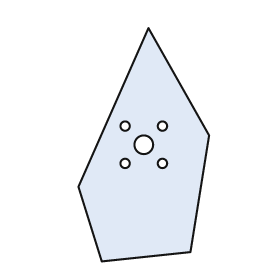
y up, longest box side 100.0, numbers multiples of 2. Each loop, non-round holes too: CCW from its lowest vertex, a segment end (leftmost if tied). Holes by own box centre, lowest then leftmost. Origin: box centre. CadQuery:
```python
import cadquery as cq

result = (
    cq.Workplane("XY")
    .moveTo(-18.0, -50.0)
    .lineTo(20.0, -46.0)
    .lineTo(28.0, 4.0)
    .lineTo(2.0, 50.0)
    .lineTo(-28.0, -18.0)
    .close()
    .moveTo(-8.0, -8.0)
    .circle(2.0)
    .moveTo(8.0, -8.0)
    .circle(2.0)
    .moveTo(0.0, 0.0)
    .circle(4.0)
    .moveTo(-8.0, 8.0)
    .circle(2.0)
    .moveTo(8.0, 8.0)
    .circle(2.0)
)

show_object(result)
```